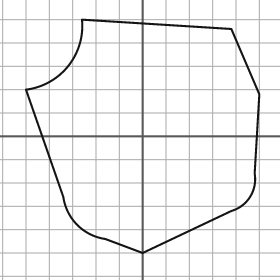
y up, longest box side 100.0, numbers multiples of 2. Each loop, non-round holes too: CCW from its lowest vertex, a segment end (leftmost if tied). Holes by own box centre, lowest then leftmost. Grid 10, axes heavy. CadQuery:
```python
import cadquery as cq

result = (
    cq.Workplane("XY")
    .moveTo(0.0, -50.0)
    .lineTo(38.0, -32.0)
    .threePointArc((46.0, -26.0), (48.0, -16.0))
    .lineTo(50.0, 18.0)
    .lineTo(38.0, 46.0)
    .lineTo(-26.0, 50.0)
    .threePointArc((-32.0, 30.0), (-50.0, 20.0))
    .lineTo(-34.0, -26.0)
    .threePointArc((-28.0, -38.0), (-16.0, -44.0))
    .close()
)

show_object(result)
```